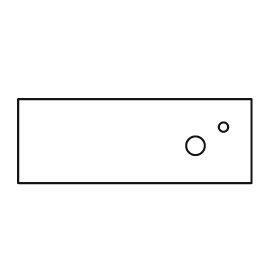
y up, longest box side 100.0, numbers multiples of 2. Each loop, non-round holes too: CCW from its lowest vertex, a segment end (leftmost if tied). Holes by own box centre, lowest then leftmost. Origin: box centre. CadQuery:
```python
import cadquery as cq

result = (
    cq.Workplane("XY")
    .moveTo(-50.0, -18.0)
    .lineTo(50.0, -18.0)
    .lineTo(50.0, 18.0)
    .lineTo(-50.0, 18.0)
    .close()
    .moveTo(26.0, -2.0)
    .circle(4.0)
    .moveTo(38.0, 6.0)
    .circle(2.0)
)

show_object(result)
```